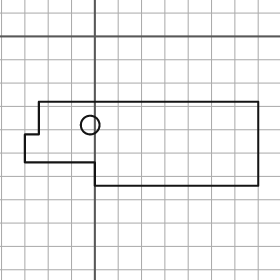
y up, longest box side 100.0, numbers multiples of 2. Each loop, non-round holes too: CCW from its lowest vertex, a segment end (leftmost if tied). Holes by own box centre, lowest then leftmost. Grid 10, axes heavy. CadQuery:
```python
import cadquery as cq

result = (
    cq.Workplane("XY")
    .moveTo(0.0, -64.0)
    .lineTo(70.0, -64.0)
    .lineTo(70.0, -28.0)
    .lineTo(-24.0, -28.0)
    .lineTo(-24.0, -42.0)
    .lineTo(-30.0, -42.0)
    .lineTo(-30.0, -54.0)
    .lineTo(0.0, -54.0)
    .close()
    .moveTo(-2.0, -38.0)
    .circle(4.0)
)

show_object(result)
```